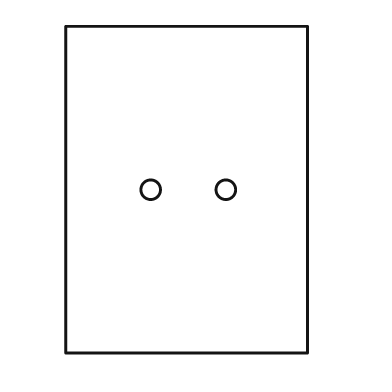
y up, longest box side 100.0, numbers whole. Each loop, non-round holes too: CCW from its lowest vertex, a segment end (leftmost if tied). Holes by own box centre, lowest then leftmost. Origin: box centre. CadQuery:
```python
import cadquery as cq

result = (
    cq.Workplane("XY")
    .moveTo(-37.0, -50.0)
    .lineTo(37.0, -50.0)
    .lineTo(37.0, 50.0)
    .lineTo(-37.0, 50.0)
    .close()
    .moveTo(-11.0, 0.0)
    .circle(3.0)
    .moveTo(12.0, 0.0)
    .circle(3.0)
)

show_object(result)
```